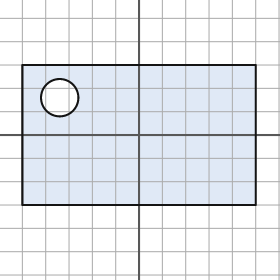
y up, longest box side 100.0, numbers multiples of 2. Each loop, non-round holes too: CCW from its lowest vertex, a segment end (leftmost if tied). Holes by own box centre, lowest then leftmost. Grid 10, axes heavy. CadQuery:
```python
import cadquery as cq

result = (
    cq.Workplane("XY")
    .moveTo(-50.0, -30.0)
    .lineTo(50.0, -30.0)
    .lineTo(50.0, 30.0)
    .lineTo(-50.0, 30.0)
    .close()
    .moveTo(-34.0, 16.0)
    .circle(8.0)
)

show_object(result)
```